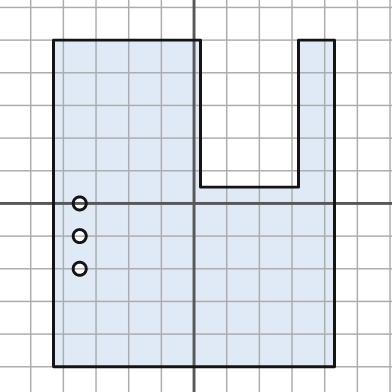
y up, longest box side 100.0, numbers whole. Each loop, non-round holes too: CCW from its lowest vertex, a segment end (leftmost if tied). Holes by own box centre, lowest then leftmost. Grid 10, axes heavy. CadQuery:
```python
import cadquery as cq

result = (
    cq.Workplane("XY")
    .moveTo(-43.0, -50.0)
    .lineTo(43.0, -50.0)
    .lineTo(43.0, 50.0)
    .lineTo(32.0, 50.0)
    .lineTo(32.0, 5.0)
    .lineTo(2.0, 5.0)
    .lineTo(2.0, 50.0)
    .lineTo(-43.0, 50.0)
    .close()
    .moveTo(-35.0, -20.0)
    .circle(2.0)
    .moveTo(-35.0, -10.0)
    .circle(2.0)
    .moveTo(-35.0, 0.0)
    .circle(2.0)
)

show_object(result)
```